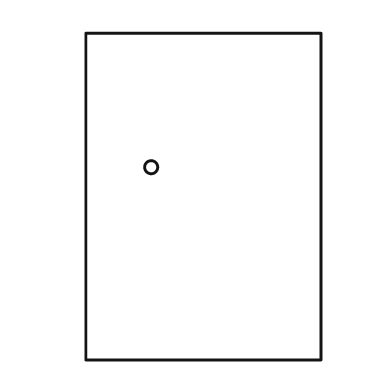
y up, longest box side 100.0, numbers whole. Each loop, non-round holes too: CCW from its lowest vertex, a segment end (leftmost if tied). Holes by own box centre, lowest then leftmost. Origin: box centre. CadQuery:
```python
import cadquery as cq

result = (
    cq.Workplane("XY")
    .moveTo(-36.0, -50.0)
    .lineTo(36.0, -50.0)
    .lineTo(36.0, 50.0)
    .lineTo(-36.0, 50.0)
    .close()
    .moveTo(-16.0, 9.0)
    .circle(2.0)
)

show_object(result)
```